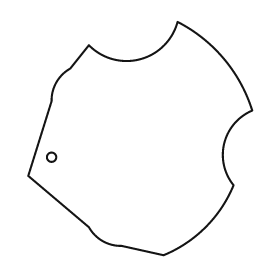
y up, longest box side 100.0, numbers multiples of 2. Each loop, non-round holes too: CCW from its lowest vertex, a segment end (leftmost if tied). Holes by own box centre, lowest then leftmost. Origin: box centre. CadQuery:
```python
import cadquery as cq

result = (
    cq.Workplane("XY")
    .moveTo(10.0, -50.0)
    .threePointArc((28.0, -38.0), (40.0, -20.0))
    .threePointArc((36.0, -2.0), (48.0, 12.0))
    .threePointArc((36.0, 34.0), (16.0, 50.0))
    .threePointArc((0.0, 34.0), (-22.0, 40.0))
    .lineTo(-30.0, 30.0)
    .threePointArc((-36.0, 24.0), (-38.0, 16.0))
    .lineTo(-48.0, -16.0)
    .lineTo(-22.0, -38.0)
    .threePointArc((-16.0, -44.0), (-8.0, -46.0))
    .close()
    .moveTo(-38.0, -8.0)
    .circle(2.0)
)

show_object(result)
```